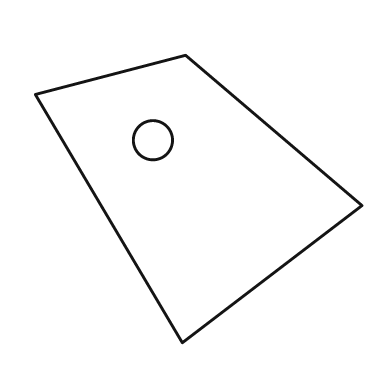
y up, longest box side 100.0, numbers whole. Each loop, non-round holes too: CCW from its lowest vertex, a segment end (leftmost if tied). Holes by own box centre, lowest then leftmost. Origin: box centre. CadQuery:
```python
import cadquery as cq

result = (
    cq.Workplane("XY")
    .moveTo(-5.0, -44.0)
    .lineTo(50.0, -2.0)
    .lineTo(-4.0, 44.0)
    .lineTo(-50.0, 32.0)
    .close()
    .moveTo(-14.0, 18.0)
    .circle(6.0)
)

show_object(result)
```